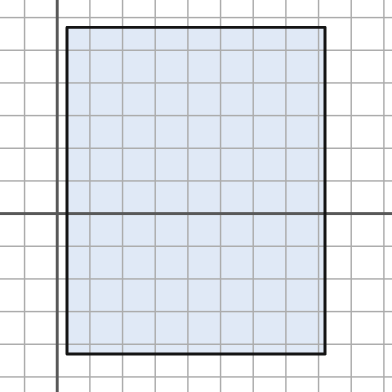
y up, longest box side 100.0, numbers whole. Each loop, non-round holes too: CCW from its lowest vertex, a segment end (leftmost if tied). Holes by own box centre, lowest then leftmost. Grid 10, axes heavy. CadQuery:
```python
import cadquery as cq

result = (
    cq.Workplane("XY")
    .moveTo(3.0, -43.0)
    .lineTo(82.0, -43.0)
    .lineTo(82.0, 57.0)
    .lineTo(3.0, 57.0)
    .close()
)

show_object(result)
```